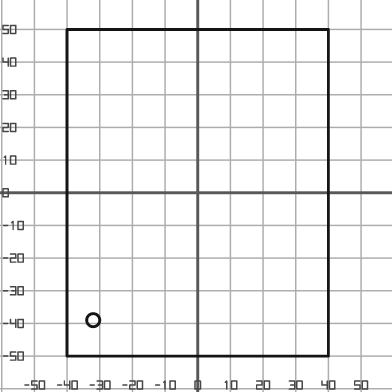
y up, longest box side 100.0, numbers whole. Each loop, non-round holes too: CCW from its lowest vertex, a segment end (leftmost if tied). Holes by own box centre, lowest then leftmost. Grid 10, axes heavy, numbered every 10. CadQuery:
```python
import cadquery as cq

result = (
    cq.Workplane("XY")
    .moveTo(-40.0, -50.0)
    .lineTo(40.0, -50.0)
    .lineTo(40.0, 50.0)
    .lineTo(-40.0, 50.0)
    .close()
    .moveTo(-32.0, -39.0)
    .circle(2.0)
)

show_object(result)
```